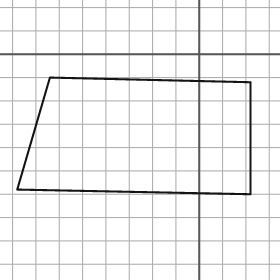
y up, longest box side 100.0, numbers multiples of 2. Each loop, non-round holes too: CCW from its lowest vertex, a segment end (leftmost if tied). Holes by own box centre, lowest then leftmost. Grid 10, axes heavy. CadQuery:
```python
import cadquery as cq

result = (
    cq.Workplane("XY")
    .moveTo(22.0, -60.0)
    .lineTo(22.0, -12.0)
    .lineTo(-64.0, -10.0)
    .lineTo(-78.0, -58.0)
    .close()
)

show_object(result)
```